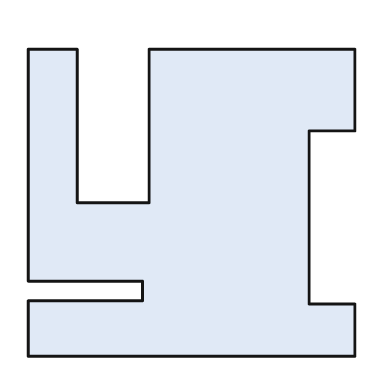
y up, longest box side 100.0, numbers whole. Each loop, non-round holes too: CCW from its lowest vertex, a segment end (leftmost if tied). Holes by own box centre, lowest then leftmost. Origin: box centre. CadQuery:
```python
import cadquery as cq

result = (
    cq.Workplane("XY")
    .moveTo(-50.0, -47.0)
    .lineTo(50.0, -47.0)
    .lineTo(50.0, -31.0)
    .lineTo(36.0, -31.0)
    .lineTo(36.0, 22.0)
    .lineTo(50.0, 22.0)
    .lineTo(50.0, 47.0)
    .lineTo(-13.0, 47.0)
    .lineTo(-13.0, 0.0)
    .lineTo(-35.0, 0.0)
    .lineTo(-35.0, 47.0)
    .lineTo(-50.0, 47.0)
    .lineTo(-50.0, -24.0)
    .lineTo(-15.0, -24.0)
    .lineTo(-15.0, -30.0)
    .lineTo(-50.0, -30.0)
    .close()
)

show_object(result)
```